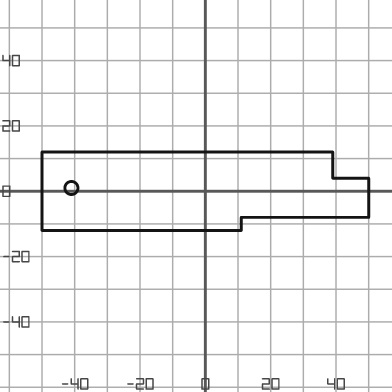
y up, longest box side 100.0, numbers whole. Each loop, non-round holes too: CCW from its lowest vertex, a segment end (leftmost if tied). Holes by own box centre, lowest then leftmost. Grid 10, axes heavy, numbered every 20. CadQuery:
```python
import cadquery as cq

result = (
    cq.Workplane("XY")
    .moveTo(-50.0, -12.0)
    .lineTo(11.0, -12.0)
    .lineTo(11.0, -8.0)
    .lineTo(50.0, -8.0)
    .lineTo(50.0, 4.0)
    .lineTo(39.0, 4.0)
    .lineTo(39.0, 12.0)
    .lineTo(-50.0, 12.0)
    .close()
    .moveTo(-41.0, 1.0)
    .circle(2.0)
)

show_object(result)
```